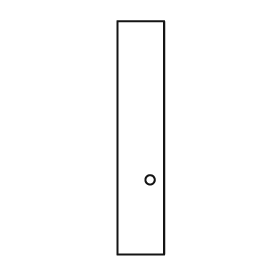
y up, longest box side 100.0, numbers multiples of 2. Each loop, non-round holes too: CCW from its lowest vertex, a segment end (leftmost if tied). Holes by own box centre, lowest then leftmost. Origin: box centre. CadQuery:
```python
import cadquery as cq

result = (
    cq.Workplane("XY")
    .moveTo(-10.0, -50.0)
    .lineTo(10.0, -50.0)
    .lineTo(10.0, 50.0)
    .lineTo(-10.0, 50.0)
    .close()
    .moveTo(4.0, -18.0)
    .circle(2.0)
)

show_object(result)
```